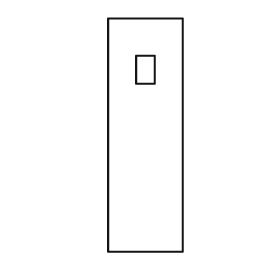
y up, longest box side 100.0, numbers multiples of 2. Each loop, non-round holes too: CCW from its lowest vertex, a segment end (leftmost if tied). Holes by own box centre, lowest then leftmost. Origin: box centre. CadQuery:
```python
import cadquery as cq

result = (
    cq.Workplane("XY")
    .moveTo(-16.0, -50.0)
    .lineTo(16.0, -50.0)
    .lineTo(16.0, 50.0)
    .lineTo(-16.0, 50.0)
    .close()
    .moveTo(-4.0, 22.0)
    .lineTo(4.0, 22.0)
    .lineTo(4.0, 34.0)
    .lineTo(-4.0, 34.0)
    .close()
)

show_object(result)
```